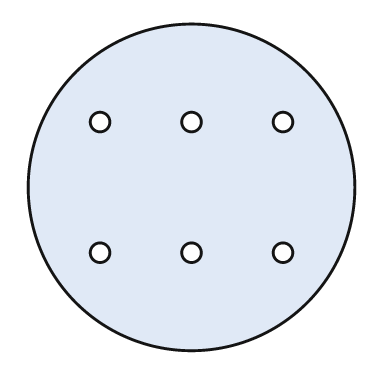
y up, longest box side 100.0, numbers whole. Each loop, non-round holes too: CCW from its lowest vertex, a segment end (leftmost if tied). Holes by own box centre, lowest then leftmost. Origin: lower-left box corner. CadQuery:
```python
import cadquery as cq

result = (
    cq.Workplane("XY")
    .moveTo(50.0, 50.0)
    .circle(50.0)
    .moveTo(22.0, 30.0)
    .circle(3.0)
    .moveTo(50.0, 30.0)
    .circle(3.0)
    .moveTo(78.0, 30.0)
    .circle(3.0)
    .moveTo(22.0, 70.0)
    .circle(3.0)
    .moveTo(50.0, 70.0)
    .circle(3.0)
    .moveTo(78.0, 70.0)
    .circle(3.0)
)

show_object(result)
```